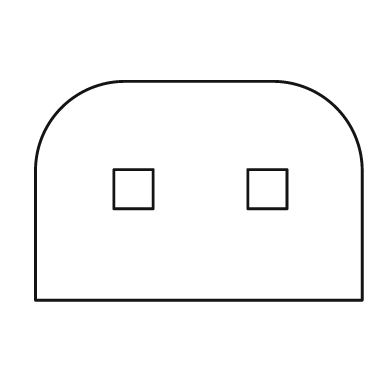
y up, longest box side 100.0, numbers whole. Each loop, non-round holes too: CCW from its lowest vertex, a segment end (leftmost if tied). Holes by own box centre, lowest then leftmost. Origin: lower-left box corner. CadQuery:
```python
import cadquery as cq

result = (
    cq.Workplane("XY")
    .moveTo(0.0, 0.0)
    .lineTo(100.0, 0.0)
    .lineTo(100.0, 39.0)
    .threePointArc((92.0, 59.0), (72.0, 67.0))
    .lineTo(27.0, 67.0)
    .threePointArc((8.0, 59.0), (0.0, 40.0))
    .close()
    .moveTo(24.0, 28.0)
    .lineTo(36.0, 28.0)
    .lineTo(36.0, 40.0)
    .lineTo(24.0, 40.0)
    .close()
    .moveTo(65.0, 28.0)
    .lineTo(77.0, 28.0)
    .lineTo(77.0, 40.0)
    .lineTo(65.0, 40.0)
    .close()
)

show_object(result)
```